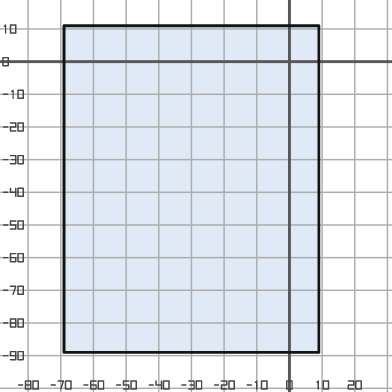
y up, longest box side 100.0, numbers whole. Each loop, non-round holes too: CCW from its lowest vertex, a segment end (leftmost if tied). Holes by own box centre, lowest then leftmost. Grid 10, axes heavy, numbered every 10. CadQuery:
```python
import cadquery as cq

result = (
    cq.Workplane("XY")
    .moveTo(-69.0, -89.0)
    .lineTo(9.0, -89.0)
    .lineTo(9.0, 11.0)
    .lineTo(-69.0, 11.0)
    .close()
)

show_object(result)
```